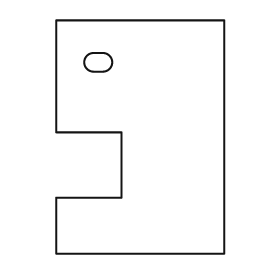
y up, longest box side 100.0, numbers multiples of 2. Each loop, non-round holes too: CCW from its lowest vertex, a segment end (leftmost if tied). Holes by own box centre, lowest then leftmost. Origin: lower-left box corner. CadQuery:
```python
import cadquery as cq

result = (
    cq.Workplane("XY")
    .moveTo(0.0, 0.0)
    .lineTo(72.0, 0.0)
    .lineTo(72.0, 100.0)
    .lineTo(0.0, 100.0)
    .lineTo(0.0, 52.0)
    .lineTo(28.0, 52.0)
    .lineTo(28.0, 24.0)
    .lineTo(0.0, 24.0)
    .close()
    .moveTo(16.0, 78.0)
    .lineTo(20.0, 78.0)
    .threePointArc((24.0, 82.0), (20.0, 86.0))
    .lineTo(16.0, 86.0)
    .threePointArc((12.0, 82.0), (16.0, 78.0))
    .close()
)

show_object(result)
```